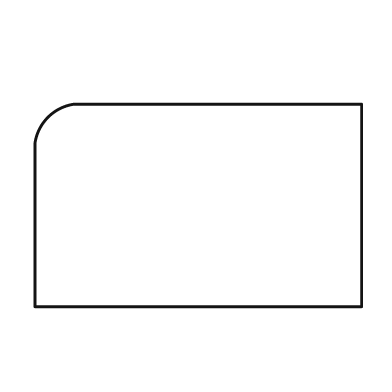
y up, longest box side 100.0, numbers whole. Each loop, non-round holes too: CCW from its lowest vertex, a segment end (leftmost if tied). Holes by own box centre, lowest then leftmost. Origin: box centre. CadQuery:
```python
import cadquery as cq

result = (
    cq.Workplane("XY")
    .moveTo(-50.0, -31.0)
    .lineTo(50.0, -31.0)
    .lineTo(50.0, 31.0)
    .lineTo(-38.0, 31.0)
    .threePointArc((-46.0, 27.0), (-50.0, 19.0))
    .close()
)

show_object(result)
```